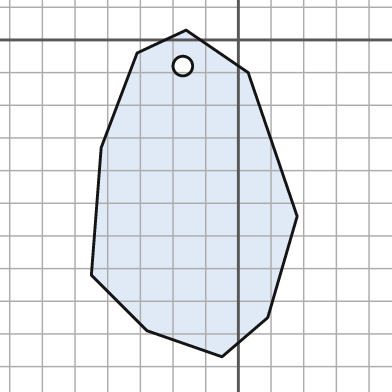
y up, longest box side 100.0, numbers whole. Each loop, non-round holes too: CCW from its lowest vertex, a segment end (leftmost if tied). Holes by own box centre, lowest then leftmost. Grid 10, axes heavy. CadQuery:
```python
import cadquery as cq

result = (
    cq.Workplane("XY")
    .moveTo(-5.0, -97.0)
    .lineTo(9.0, -85.0)
    .lineTo(18.0, -54.0)
    .lineTo(3.0, -10.0)
    .lineTo(-16.0, 3.0)
    .lineTo(-31.0, -4.0)
    .lineTo(-42.0, -33.0)
    .lineTo(-45.0, -72.0)
    .lineTo(-28.0, -89.0)
    .close()
    .moveTo(-17.0, -8.0)
    .circle(3.0)
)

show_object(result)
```